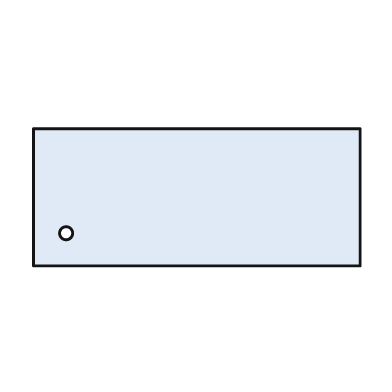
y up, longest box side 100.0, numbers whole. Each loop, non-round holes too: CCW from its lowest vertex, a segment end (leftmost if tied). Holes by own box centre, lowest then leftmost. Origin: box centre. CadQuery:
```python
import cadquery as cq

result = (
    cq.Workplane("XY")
    .moveTo(-50.0, -21.0)
    .lineTo(50.0, -21.0)
    .lineTo(50.0, 21.0)
    .lineTo(-50.0, 21.0)
    .close()
    .moveTo(-40.0, -11.0)
    .circle(2.0)
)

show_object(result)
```